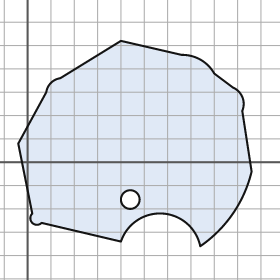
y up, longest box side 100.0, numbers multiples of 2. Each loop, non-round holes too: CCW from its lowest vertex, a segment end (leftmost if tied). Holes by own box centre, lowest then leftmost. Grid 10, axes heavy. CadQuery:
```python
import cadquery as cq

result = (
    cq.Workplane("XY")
    .moveTo(74.0, -36.0)
    .threePointArc((88.0, -22.0), (96.0, -4.0))
    .lineTo(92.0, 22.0)
    .threePointArc((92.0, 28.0), (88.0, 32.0))
    .lineTo(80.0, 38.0)
    .threePointArc((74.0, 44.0), (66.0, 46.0))
    .lineTo(40.0, 52.0)
    .lineTo(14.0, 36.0)
    .threePointArc((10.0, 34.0), (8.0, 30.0))
    .lineTo(-4.0, 8.0)
    .lineTo(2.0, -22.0)
    .threePointArc((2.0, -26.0), (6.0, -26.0))
    .lineTo(40.0, -34.0)
    .threePointArc((58.0, -22.0), (74.0, -36.0))
    .close()
    .moveTo(44.0, -16.0)
    .circle(4.0)
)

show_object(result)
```